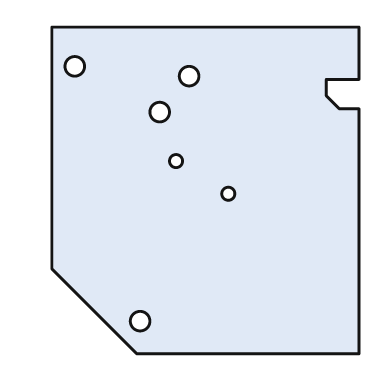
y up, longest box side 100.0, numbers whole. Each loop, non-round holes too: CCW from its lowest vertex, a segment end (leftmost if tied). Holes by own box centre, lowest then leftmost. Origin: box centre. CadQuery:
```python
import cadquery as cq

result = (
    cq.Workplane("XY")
    .moveTo(-21.0, -50.0)
    .lineTo(47.0, -50.0)
    .lineTo(47.0, 25.0)
    .lineTo(41.0, 25.0)
    .lineTo(37.0, 29.0)
    .lineTo(37.0, 34.0)
    .lineTo(47.0, 34.0)
    .lineTo(47.0, 50.0)
    .lineTo(-47.0, 50.0)
    .lineTo(-47.0, -24.0)
    .close()
    .moveTo(-20.0, -40.0)
    .circle(3.0)
    .moveTo(7.0, -1.0)
    .circle(2.0)
    .moveTo(-9.0, 9.0)
    .circle(2.0)
    .moveTo(-14.0, 24.0)
    .circle(3.0)
    .moveTo(-5.0, 35.0)
    .circle(3.0)
    .moveTo(-40.0, 38.0)
    .circle(3.0)
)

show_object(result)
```